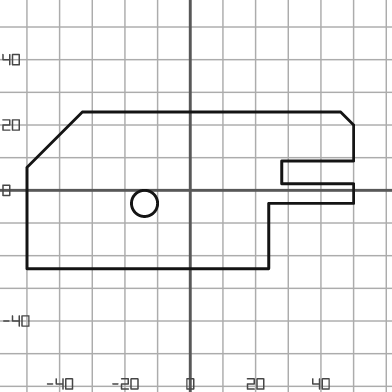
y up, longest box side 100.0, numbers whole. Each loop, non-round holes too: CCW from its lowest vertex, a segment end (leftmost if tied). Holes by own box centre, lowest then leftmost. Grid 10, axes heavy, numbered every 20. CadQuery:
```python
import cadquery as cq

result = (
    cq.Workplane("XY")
    .moveTo(-50.0, -24.0)
    .lineTo(24.0, -24.0)
    .lineTo(24.0, -4.0)
    .lineTo(50.0, -4.0)
    .lineTo(50.0, 2.0)
    .lineTo(28.0, 2.0)
    .lineTo(28.0, 9.0)
    .lineTo(50.0, 9.0)
    .lineTo(50.0, 20.0)
    .lineTo(46.0, 24.0)
    .lineTo(-33.0, 24.0)
    .lineTo(-50.0, 7.0)
    .close()
    .moveTo(-14.0, -4.0)
    .circle(4.0)
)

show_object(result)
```